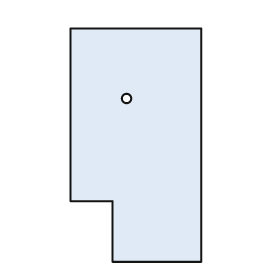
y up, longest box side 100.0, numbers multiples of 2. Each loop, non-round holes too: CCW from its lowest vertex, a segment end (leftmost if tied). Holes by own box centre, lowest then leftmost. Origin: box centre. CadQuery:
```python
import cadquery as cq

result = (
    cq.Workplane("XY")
    .moveTo(-10.0, -50.0)
    .lineTo(28.0, -50.0)
    .lineTo(28.0, 50.0)
    .lineTo(-28.0, 50.0)
    .lineTo(-28.0, -24.0)
    .lineTo(-10.0, -24.0)
    .close()
    .moveTo(-4.0, 20.0)
    .circle(2.0)
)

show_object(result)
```